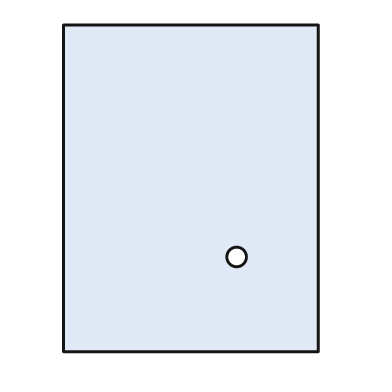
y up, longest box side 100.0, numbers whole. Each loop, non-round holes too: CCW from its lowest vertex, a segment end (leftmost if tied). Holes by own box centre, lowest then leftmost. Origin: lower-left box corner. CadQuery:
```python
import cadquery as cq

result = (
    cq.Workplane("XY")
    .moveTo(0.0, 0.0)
    .lineTo(78.0, 0.0)
    .lineTo(78.0, 100.0)
    .lineTo(0.0, 100.0)
    .close()
    .moveTo(53.0, 29.0)
    .circle(3.0)
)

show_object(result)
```